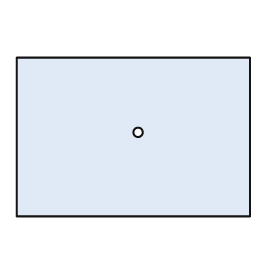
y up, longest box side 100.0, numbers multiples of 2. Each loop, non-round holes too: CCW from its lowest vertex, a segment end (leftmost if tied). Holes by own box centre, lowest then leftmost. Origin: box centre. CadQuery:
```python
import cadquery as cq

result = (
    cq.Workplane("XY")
    .moveTo(-50.0, -34.0)
    .lineTo(50.0, -34.0)
    .lineTo(50.0, 34.0)
    .lineTo(-50.0, 34.0)
    .close()
    .moveTo(2.0, 2.0)
    .circle(2.0)
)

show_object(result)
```